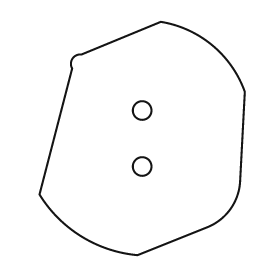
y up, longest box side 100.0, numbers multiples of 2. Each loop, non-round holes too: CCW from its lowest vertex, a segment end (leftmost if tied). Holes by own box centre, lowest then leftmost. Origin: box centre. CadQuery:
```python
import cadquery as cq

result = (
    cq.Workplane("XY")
    .moveTo(-2.0, -50.0)
    .lineTo(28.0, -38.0)
    .threePointArc((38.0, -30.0), (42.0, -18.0))
    .lineTo(44.0, 20.0)
    .threePointArc((30.0, 40.0), (8.0, 50.0))
    .lineTo(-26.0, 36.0)
    .threePointArc((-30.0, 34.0), (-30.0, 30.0))
    .lineTo(-44.0, -24.0)
    .threePointArc((-26.0, -42.0), (-2.0, -50.0))
    .close()
    .moveTo(0.0, -12.0)
    .circle(4.0)
    .moveTo(0.0, 12.0)
    .circle(4.0)
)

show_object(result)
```